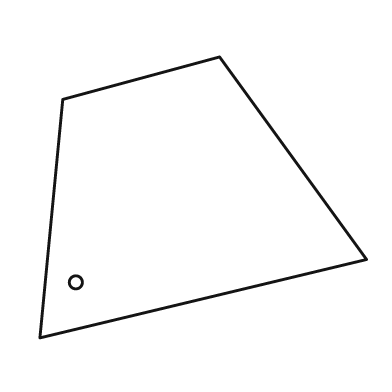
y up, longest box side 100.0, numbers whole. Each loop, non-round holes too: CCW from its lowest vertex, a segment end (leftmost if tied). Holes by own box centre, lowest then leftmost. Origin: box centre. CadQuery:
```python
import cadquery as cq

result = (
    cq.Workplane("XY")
    .moveTo(-50.0, -43.0)
    .lineTo(50.0, -19.0)
    .lineTo(5.0, 43.0)
    .lineTo(-43.0, 30.0)
    .close()
    .moveTo(-39.0, -26.0)
    .circle(2.0)
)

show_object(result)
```